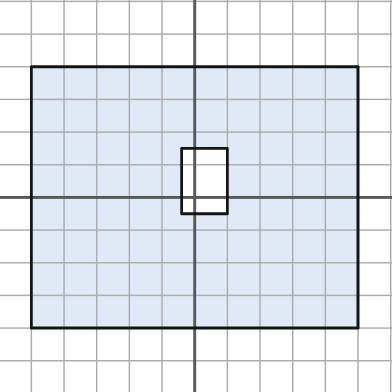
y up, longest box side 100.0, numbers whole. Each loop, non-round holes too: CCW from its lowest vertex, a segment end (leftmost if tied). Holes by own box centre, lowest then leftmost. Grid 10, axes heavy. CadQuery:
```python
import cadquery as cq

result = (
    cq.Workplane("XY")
    .moveTo(-50.0, -40.0)
    .lineTo(50.0, -40.0)
    .lineTo(50.0, 40.0)
    .lineTo(-50.0, 40.0)
    .close()
    .moveTo(-4.0, -5.0)
    .lineTo(10.0, -5.0)
    .lineTo(10.0, 15.0)
    .lineTo(-4.0, 15.0)
    .close()
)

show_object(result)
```